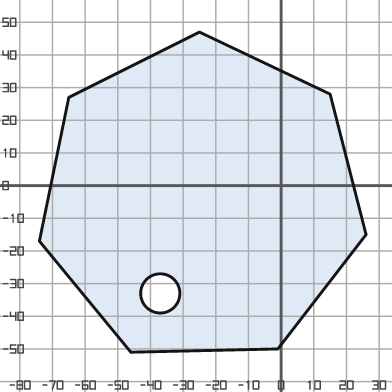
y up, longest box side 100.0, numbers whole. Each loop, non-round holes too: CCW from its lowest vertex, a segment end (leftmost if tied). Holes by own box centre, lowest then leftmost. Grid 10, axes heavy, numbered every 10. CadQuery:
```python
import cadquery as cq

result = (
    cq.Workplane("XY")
    .moveTo(-46.0, -51.0)
    .lineTo(-1.0, -50.0)
    .lineTo(26.0, -15.0)
    .lineTo(15.0, 28.0)
    .lineTo(-25.0, 47.0)
    .lineTo(-65.0, 27.0)
    .lineTo(-74.0, -17.0)
    .close()
    .moveTo(-37.0, -33.0)
    .circle(6.0)
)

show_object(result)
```